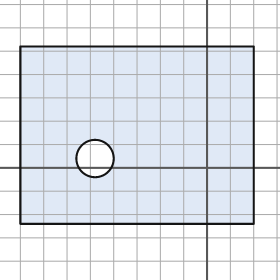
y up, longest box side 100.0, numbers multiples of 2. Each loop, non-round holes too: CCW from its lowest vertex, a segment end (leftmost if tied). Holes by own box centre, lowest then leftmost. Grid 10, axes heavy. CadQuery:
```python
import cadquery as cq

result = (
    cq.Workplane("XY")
    .moveTo(-80.0, -24.0)
    .lineTo(20.0, -24.0)
    .lineTo(20.0, 52.0)
    .lineTo(-80.0, 52.0)
    .close()
    .moveTo(-48.0, 4.0)
    .circle(8.0)
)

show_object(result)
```